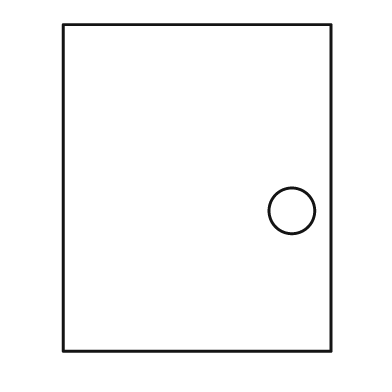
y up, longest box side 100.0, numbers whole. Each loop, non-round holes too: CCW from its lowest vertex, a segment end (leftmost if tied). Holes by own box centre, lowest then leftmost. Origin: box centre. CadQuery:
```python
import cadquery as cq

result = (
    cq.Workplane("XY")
    .moveTo(-41.0, -50.0)
    .lineTo(41.0, -50.0)
    .lineTo(41.0, 50.0)
    .lineTo(-41.0, 50.0)
    .close()
    .moveTo(29.0, -7.0)
    .circle(7.0)
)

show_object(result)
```